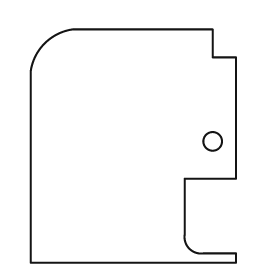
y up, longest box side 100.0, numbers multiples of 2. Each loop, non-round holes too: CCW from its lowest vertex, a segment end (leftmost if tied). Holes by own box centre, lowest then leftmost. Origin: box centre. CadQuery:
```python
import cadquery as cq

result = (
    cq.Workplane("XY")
    .moveTo(-44.0, -50.0)
    .lineTo(44.0, -50.0)
    .lineTo(44.0, -46.0)
    .lineTo(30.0, -46.0)
    .threePointArc((24.0, -44.0), (22.0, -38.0))
    .lineTo(22.0, -14.0)
    .lineTo(44.0, -14.0)
    .lineTo(44.0, 38.0)
    .lineTo(34.0, 38.0)
    .lineTo(34.0, 50.0)
    .lineTo(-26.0, 50.0)
    .threePointArc((-38.0, 44.0), (-44.0, 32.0))
    .close()
    .moveTo(34.0, 2.0)
    .circle(4.0)
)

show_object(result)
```